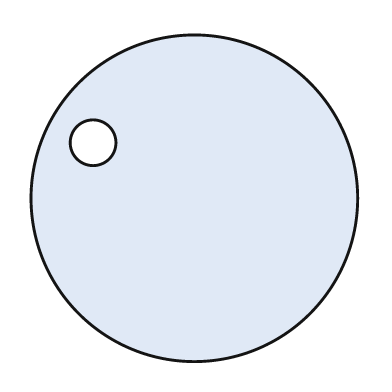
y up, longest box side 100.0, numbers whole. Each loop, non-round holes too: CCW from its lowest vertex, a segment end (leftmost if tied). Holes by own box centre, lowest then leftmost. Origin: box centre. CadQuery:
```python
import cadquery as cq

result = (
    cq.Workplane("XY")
    .moveTo(0.0, 0.0)
    .circle(50.0)
    .moveTo(-31.0, 17.0)
    .circle(7.0)
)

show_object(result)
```